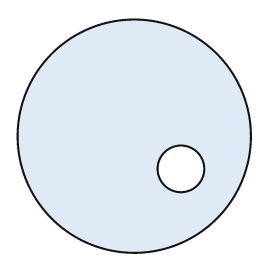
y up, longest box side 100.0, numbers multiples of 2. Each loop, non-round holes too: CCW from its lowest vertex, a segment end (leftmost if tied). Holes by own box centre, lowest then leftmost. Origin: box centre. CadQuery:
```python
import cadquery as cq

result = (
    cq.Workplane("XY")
    .moveTo(0.0, 0.0)
    .circle(50.0)
    .moveTo(20.0, -14.0)
    .circle(10.0)
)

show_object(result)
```